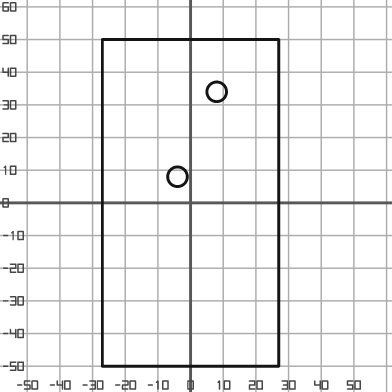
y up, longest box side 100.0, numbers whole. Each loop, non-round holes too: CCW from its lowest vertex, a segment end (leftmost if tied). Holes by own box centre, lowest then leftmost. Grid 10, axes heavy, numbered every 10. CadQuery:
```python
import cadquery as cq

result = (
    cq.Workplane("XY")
    .moveTo(-27.0, -50.0)
    .lineTo(27.0, -50.0)
    .lineTo(27.0, 50.0)
    .lineTo(-27.0, 50.0)
    .close()
    .moveTo(-4.0, 8.0)
    .circle(3.0)
    .moveTo(8.0, 34.0)
    .circle(3.0)
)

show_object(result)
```